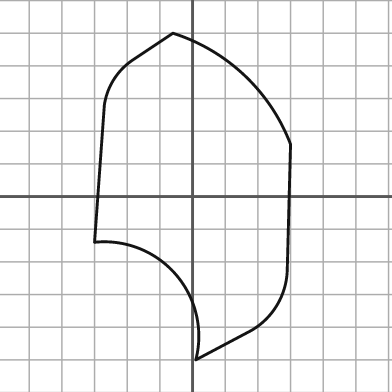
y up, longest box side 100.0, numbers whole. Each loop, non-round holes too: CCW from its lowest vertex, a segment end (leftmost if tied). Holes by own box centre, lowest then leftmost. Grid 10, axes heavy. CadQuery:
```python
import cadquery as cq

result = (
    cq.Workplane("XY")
    .moveTo(1.0, -50.0)
    .lineTo(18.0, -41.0)
    .threePointArc((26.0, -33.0), (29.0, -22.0))
    .lineTo(30.0, 16.0)
    .threePointArc((16.0, 37.0), (-6.0, 50.0))
    .lineTo(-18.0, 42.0)
    .threePointArc((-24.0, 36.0), (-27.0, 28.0))
    .lineTo(-30.0, -14.0)
    .threePointArc((-5.0, -24.0), (1.0, -50.0))
    .close()
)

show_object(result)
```